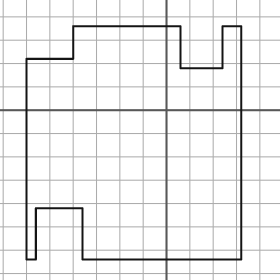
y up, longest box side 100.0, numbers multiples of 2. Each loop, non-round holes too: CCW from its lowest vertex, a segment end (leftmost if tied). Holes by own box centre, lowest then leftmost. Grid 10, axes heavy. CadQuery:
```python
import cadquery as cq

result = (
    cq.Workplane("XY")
    .moveTo(-60.0, -64.0)
    .lineTo(-56.0, -64.0)
    .lineTo(-56.0, -42.0)
    .lineTo(-36.0, -42.0)
    .lineTo(-36.0, -64.0)
    .lineTo(32.0, -64.0)
    .lineTo(32.0, 36.0)
    .lineTo(24.0, 36.0)
    .lineTo(24.0, 18.0)
    .lineTo(6.0, 18.0)
    .lineTo(6.0, 36.0)
    .lineTo(-40.0, 36.0)
    .lineTo(-40.0, 22.0)
    .lineTo(-60.0, 22.0)
    .close()
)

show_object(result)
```